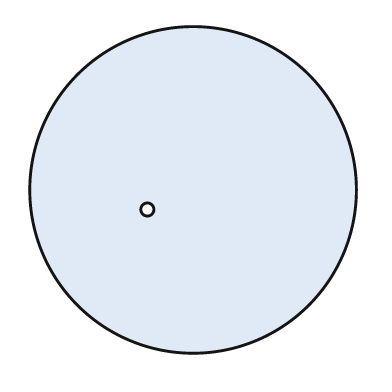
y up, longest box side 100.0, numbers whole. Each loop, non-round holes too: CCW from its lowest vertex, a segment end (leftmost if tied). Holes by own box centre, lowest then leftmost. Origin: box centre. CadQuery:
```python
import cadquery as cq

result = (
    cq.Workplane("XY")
    .moveTo(0.0, 0.0)
    .circle(50.0)
    .moveTo(-14.0, -6.0)
    .circle(2.0)
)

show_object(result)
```